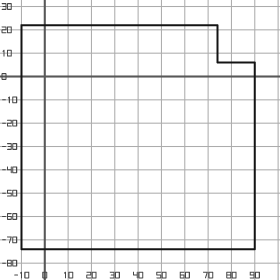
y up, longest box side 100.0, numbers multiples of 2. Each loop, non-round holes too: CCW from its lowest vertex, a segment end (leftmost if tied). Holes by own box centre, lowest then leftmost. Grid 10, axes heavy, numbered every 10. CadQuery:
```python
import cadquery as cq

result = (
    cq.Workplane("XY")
    .moveTo(-10.0, -74.0)
    .lineTo(90.0, -74.0)
    .lineTo(90.0, 6.0)
    .lineTo(74.0, 6.0)
    .lineTo(74.0, 22.0)
    .lineTo(-10.0, 22.0)
    .close()
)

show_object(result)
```